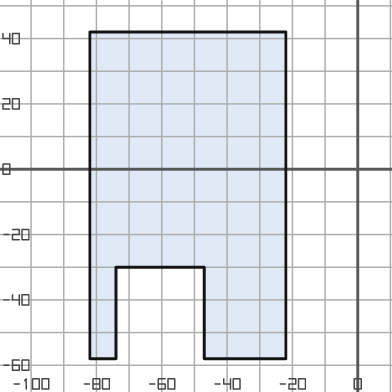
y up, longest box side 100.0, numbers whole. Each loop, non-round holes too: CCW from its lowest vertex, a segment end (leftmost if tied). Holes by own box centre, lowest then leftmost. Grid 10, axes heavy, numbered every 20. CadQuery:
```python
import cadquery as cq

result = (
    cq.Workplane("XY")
    .moveTo(-82.0, -58.0)
    .lineTo(-74.0, -58.0)
    .lineTo(-74.0, -30.0)
    .lineTo(-47.0, -30.0)
    .lineTo(-47.0, -58.0)
    .lineTo(-22.0, -58.0)
    .lineTo(-22.0, 42.0)
    .lineTo(-82.0, 42.0)
    .close()
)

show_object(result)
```